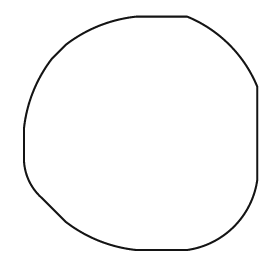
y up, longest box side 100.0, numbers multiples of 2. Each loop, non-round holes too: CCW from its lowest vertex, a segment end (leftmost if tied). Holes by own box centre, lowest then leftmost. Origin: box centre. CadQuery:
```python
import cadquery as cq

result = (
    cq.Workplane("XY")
    .moveTo(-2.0, -50.0)
    .lineTo(20.0, -50.0)
    .threePointArc((40.0, -40.0), (50.0, -20.0))
    .lineTo(50.0, 20.0)
    .threePointArc((38.0, 38.0), (20.0, 50.0))
    .lineTo(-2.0, 50.0)
    .threePointArc((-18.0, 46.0), (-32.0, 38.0))
    .lineTo(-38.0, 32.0)
    .threePointArc((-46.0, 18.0), (-50.0, 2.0))
    .lineTo(-50.0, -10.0)
    .threePointArc((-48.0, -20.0), (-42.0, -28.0))
    .lineTo(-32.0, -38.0)
    .threePointArc((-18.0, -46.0), (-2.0, -50.0))
    .close()
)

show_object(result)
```